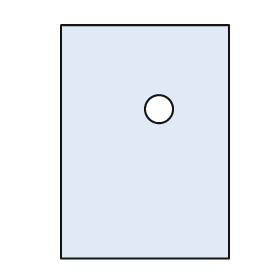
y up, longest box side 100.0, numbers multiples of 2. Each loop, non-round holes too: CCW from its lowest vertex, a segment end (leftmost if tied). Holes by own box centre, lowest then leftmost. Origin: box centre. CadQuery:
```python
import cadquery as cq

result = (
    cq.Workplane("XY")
    .moveTo(-36.0, -50.0)
    .lineTo(36.0, -50.0)
    .lineTo(36.0, 50.0)
    .lineTo(-36.0, 50.0)
    .close()
    .moveTo(6.0, 14.0)
    .circle(6.0)
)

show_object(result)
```